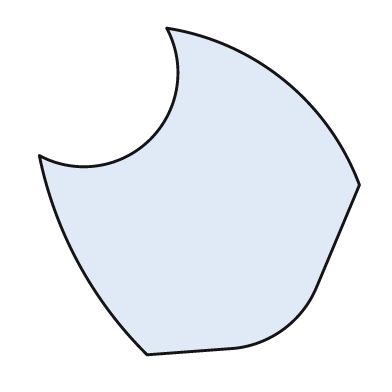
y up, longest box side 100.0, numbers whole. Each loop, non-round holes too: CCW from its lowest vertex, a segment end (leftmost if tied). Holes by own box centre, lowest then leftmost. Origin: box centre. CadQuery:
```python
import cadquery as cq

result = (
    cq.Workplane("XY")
    .moveTo(-16.0, -50.0)
    .lineTo(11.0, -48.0)
    .threePointArc((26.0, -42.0), (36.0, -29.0))
    .lineTo(49.0, 2.0)
    .threePointArc((26.0, 34.0), (-10.0, 50.0))
    .threePointArc((-15.0, 16.0), (-49.0, 11.0))
    .threePointArc((-37.0, -22.0), (-16.0, -50.0))
    .close()
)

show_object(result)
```